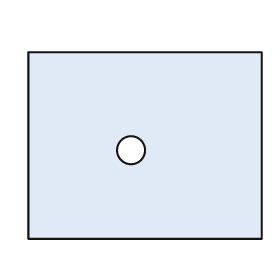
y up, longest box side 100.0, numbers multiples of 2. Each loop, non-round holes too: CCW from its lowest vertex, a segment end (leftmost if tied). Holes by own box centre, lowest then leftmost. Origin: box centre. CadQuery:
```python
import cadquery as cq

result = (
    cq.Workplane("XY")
    .moveTo(-50.0, -40.0)
    .lineTo(50.0, -40.0)
    .lineTo(50.0, 40.0)
    .lineTo(-50.0, 40.0)
    .close()
    .moveTo(-6.0, -2.0)
    .circle(6.0)
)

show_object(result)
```